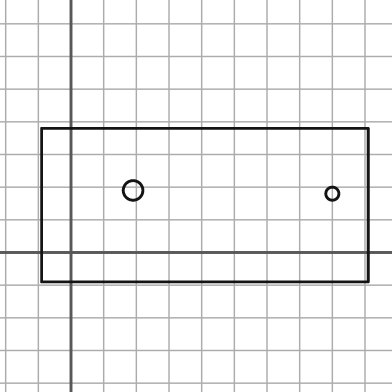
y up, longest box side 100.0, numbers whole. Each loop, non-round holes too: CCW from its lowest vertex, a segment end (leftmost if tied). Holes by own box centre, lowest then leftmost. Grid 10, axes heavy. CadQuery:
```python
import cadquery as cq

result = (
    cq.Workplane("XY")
    .moveTo(-9.0, -9.0)
    .lineTo(91.0, -9.0)
    .lineTo(91.0, 38.0)
    .lineTo(-9.0, 38.0)
    .close()
    .moveTo(80.0, 18.0)
    .circle(2.0)
    .moveTo(19.0, 19.0)
    .circle(3.0)
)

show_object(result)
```